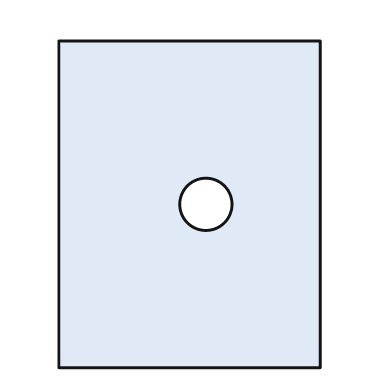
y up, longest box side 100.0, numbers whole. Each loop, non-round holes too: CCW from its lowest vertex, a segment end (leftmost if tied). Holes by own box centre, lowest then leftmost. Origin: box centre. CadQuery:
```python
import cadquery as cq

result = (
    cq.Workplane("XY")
    .moveTo(-40.0, -50.0)
    .lineTo(40.0, -50.0)
    .lineTo(40.0, 50.0)
    .lineTo(-40.0, 50.0)
    .close()
    .moveTo(5.0, 0.0)
    .circle(8.0)
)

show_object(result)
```